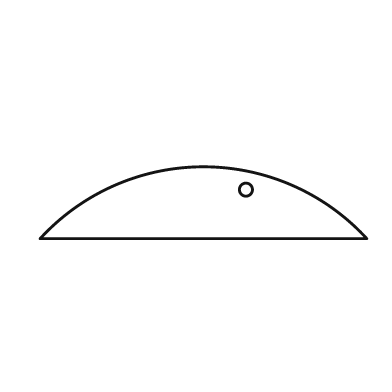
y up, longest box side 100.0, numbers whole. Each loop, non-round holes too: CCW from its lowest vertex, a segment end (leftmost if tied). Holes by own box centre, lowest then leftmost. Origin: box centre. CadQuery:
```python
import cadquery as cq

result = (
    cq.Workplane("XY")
    .moveTo(-50.0, -11.0)
    .lineTo(50.0, -11.0)
    .threePointArc((0.0, 11.0), (-50.0, -11.0))
    .close()
    .moveTo(13.0, 4.0)
    .circle(2.0)
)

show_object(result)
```